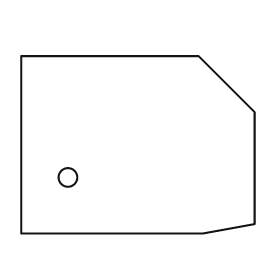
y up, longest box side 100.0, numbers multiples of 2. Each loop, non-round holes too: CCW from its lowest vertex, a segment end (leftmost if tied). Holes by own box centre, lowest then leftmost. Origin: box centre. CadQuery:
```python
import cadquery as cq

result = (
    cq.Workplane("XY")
    .moveTo(-50.0, -38.0)
    .lineTo(28.0, -38.0)
    .lineTo(50.0, -34.0)
    .lineTo(50.0, 14.0)
    .lineTo(26.0, 38.0)
    .lineTo(-50.0, 38.0)
    .close()
    .moveTo(-30.0, -14.0)
    .circle(4.0)
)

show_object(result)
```